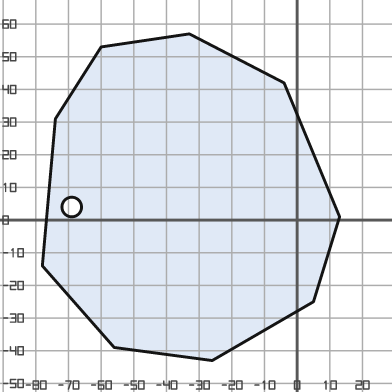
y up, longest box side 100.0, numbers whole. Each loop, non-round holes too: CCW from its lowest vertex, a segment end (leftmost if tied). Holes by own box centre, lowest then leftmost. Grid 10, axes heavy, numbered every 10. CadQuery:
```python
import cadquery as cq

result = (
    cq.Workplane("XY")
    .moveTo(-26.0, -43.0)
    .lineTo(5.0, -25.0)
    .lineTo(13.0, 1.0)
    .lineTo(-4.0, 42.0)
    .lineTo(-33.0, 57.0)
    .lineTo(-60.0, 53.0)
    .lineTo(-74.0, 31.0)
    .lineTo(-78.0, -14.0)
    .lineTo(-56.0, -39.0)
    .close()
    .moveTo(-69.0, 4.0)
    .circle(3.0)
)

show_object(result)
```